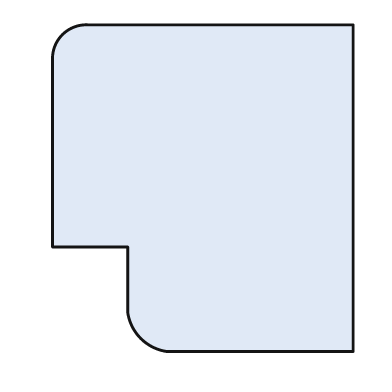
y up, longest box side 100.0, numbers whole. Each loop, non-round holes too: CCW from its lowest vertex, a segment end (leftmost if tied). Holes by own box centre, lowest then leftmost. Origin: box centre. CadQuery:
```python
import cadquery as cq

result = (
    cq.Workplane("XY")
    .moveTo(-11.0, -50.0)
    .lineTo(46.0, -50.0)
    .lineTo(46.0, 50.0)
    .lineTo(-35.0, 50.0)
    .threePointArc((-43.0, 47.0), (-46.0, 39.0))
    .lineTo(-46.0, -18.0)
    .lineTo(-23.0, -18.0)
    .lineTo(-23.0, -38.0)
    .threePointArc((-19.0, -46.0), (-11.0, -50.0))
    .close()
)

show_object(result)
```